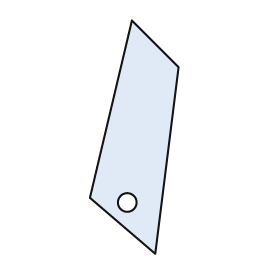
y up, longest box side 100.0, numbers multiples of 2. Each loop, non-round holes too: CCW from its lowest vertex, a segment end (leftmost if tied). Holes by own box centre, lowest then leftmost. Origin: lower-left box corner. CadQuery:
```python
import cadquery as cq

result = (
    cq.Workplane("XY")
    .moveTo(28.0, 0.0)
    .lineTo(38.0, 80.0)
    .lineTo(18.0, 100.0)
    .lineTo(0.0, 24.0)
    .close()
    .moveTo(16.0, 22.0)
    .circle(4.0)
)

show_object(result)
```